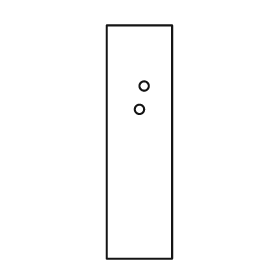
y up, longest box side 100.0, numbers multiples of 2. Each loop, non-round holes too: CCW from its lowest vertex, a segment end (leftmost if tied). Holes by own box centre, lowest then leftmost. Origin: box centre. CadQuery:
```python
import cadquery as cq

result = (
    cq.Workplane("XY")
    .moveTo(-14.0, -50.0)
    .lineTo(14.0, -50.0)
    .lineTo(14.0, 50.0)
    .lineTo(-14.0, 50.0)
    .close()
    .moveTo(0.0, 14.0)
    .circle(2.0)
    .moveTo(2.0, 24.0)
    .circle(2.0)
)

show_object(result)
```